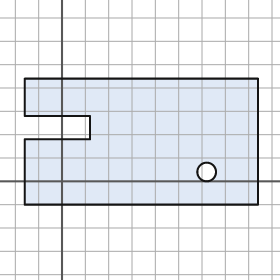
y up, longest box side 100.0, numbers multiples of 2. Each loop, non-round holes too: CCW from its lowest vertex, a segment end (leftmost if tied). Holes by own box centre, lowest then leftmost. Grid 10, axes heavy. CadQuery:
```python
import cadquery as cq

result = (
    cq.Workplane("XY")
    .moveTo(-16.0, -10.0)
    .lineTo(84.0, -10.0)
    .lineTo(84.0, 44.0)
    .lineTo(-16.0, 44.0)
    .lineTo(-16.0, 28.0)
    .lineTo(12.0, 28.0)
    .lineTo(12.0, 18.0)
    .lineTo(-16.0, 18.0)
    .close()
    .moveTo(62.0, 4.0)
    .circle(4.0)
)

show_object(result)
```